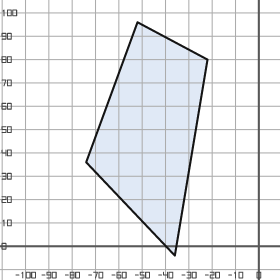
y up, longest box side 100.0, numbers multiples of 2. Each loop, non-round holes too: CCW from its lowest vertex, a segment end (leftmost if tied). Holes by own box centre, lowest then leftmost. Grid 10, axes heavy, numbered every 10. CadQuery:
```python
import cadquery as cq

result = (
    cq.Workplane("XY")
    .moveTo(-36.0, -4.0)
    .lineTo(-22.0, 80.0)
    .lineTo(-52.0, 96.0)
    .lineTo(-74.0, 36.0)
    .close()
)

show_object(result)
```